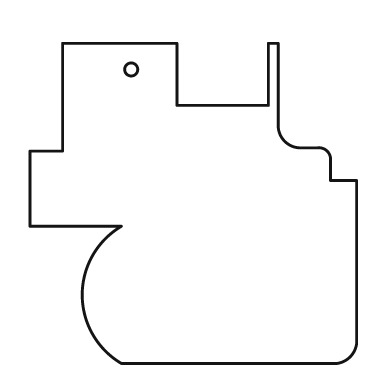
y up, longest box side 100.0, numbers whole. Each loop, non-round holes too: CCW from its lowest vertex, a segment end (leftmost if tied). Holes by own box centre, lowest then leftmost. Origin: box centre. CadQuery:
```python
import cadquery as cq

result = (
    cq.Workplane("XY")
    .moveTo(-22.0, -49.0)
    .lineTo(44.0, -49.0)
    .threePointArc((48.0, -47.0), (50.0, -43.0))
    .lineTo(50.0, 7.0)
    .lineTo(42.0, 7.0)
    .lineTo(42.0, 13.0)
    .threePointArc((41.0, 16.0), (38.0, 17.0))
    .lineTo(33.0, 17.0)
    .threePointArc((28.0, 19.0), (26.0, 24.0))
    .lineTo(26.0, 49.0)
    .lineTo(23.0, 49.0)
    .lineTo(23.0, 30.0)
    .lineTo(-5.0, 30.0)
    .lineTo(-5.0, 49.0)
    .lineTo(-40.0, 49.0)
    .lineTo(-40.0, 16.0)
    .lineTo(-50.0, 16.0)
    .lineTo(-50.0, -7.0)
    .lineTo(-22.0, -7.0)
    .threePointArc((-34.0, -28.0), (-22.0, -49.0))
    .close()
    .moveTo(-19.0, 41.0)
    .circle(2.0)
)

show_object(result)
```